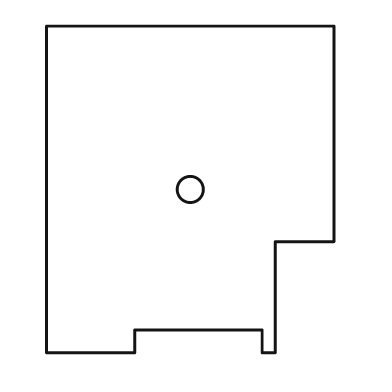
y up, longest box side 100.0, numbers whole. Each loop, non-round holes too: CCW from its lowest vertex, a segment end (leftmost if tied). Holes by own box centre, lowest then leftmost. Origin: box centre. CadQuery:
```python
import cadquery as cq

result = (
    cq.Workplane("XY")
    .moveTo(-44.0, -50.0)
    .lineTo(-17.0, -50.0)
    .lineTo(-17.0, -43.0)
    .lineTo(22.0, -43.0)
    .lineTo(22.0, -50.0)
    .lineTo(26.0, -50.0)
    .lineTo(26.0, -16.0)
    .lineTo(44.0, -16.0)
    .lineTo(44.0, 50.0)
    .lineTo(-44.0, 50.0)
    .close()
    .moveTo(0.0, 0.0)
    .circle(4.0)
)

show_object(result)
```